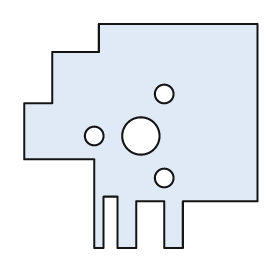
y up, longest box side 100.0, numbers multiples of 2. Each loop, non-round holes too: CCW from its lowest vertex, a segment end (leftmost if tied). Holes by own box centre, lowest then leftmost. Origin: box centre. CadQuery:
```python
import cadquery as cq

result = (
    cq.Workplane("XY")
    .moveTo(-20.0, -48.0)
    .lineTo(-16.0, -48.0)
    .lineTo(-16.0, -26.0)
    .lineTo(-10.0, -26.0)
    .lineTo(-10.0, -48.0)
    .lineTo(-2.0, -48.0)
    .lineTo(-2.0, -28.0)
    .lineTo(10.0, -28.0)
    .lineTo(10.0, -48.0)
    .lineTo(18.0, -48.0)
    .lineTo(18.0, -28.0)
    .lineTo(50.0, -28.0)
    .lineTo(50.0, 48.0)
    .lineTo(-18.0, 48.0)
    .lineTo(-18.0, 36.0)
    .lineTo(-38.0, 36.0)
    .lineTo(-38.0, 14.0)
    .lineTo(-50.0, 14.0)
    .lineTo(-50.0, -10.0)
    .lineTo(-20.0, -10.0)
    .close()
    .moveTo(10.0, -18.0)
    .circle(4.0)
    .moveTo(-20.0, 0.0)
    .circle(4.0)
    .moveTo(0.0, 0.0)
    .circle(8.0)
    .moveTo(10.0, 18.0)
    .circle(4.0)
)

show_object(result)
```